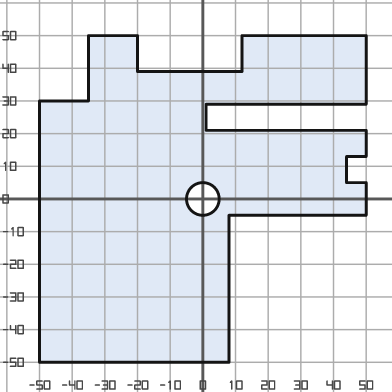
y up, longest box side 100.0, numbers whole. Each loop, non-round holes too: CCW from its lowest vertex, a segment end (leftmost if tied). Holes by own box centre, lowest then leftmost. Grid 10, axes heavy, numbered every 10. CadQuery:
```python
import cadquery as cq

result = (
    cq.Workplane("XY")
    .moveTo(-50.0, -50.0)
    .lineTo(8.0, -50.0)
    .lineTo(8.0, -5.0)
    .lineTo(50.0, -5.0)
    .lineTo(50.0, 5.0)
    .lineTo(44.0, 5.0)
    .lineTo(44.0, 13.0)
    .lineTo(50.0, 13.0)
    .lineTo(50.0, 21.0)
    .lineTo(1.0, 21.0)
    .lineTo(1.0, 29.0)
    .lineTo(50.0, 29.0)
    .lineTo(50.0, 50.0)
    .lineTo(12.0, 50.0)
    .lineTo(12.0, 39.0)
    .lineTo(-20.0, 39.0)
    .lineTo(-20.0, 50.0)
    .lineTo(-35.0, 50.0)
    .lineTo(-35.0, 30.0)
    .lineTo(-50.0, 30.0)
    .close()
    .moveTo(0.0, 0.0)
    .circle(5.0)
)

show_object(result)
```